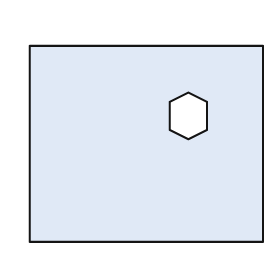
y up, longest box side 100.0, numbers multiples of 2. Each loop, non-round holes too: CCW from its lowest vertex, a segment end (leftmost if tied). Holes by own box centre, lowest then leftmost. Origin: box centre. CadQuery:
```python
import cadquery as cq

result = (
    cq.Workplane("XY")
    .moveTo(-50.0, -42.0)
    .lineTo(50.0, -42.0)
    .lineTo(50.0, 42.0)
    .lineTo(-50.0, 42.0)
    .close()
    .moveTo(18.0, 2.0)
    .lineTo(26.0, 6.0)
    .lineTo(26.0, 18.0)
    .lineTo(18.0, 22.0)
    .lineTo(10.0, 18.0)
    .lineTo(10.0, 6.0)
    .close()
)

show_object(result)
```